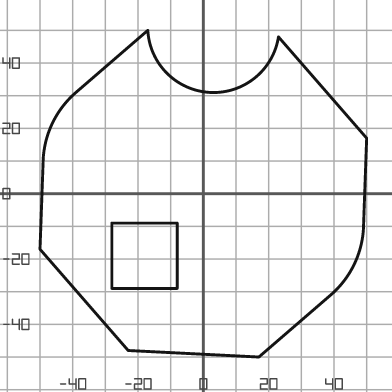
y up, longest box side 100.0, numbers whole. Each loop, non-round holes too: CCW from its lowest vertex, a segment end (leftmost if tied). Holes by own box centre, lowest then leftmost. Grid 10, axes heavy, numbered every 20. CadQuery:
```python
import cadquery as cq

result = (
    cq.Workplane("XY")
    .moveTo(17.0, -50.0)
    .lineTo(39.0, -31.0)
    .threePointArc((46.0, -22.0), (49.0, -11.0))
    .lineTo(50.0, 17.0)
    .lineTo(23.0, 48.0)
    .threePointArc((2.0, 31.0), (-17.0, 50.0))
    .lineTo(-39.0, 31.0)
    .threePointArc((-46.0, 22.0), (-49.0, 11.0))
    .lineTo(-50.0, -17.0)
    .lineTo(-23.0, -48.0)
    .close()
    .moveTo(-28.0, -29.0)
    .lineTo(-8.0, -29.0)
    .lineTo(-8.0, -9.0)
    .lineTo(-28.0, -9.0)
    .close()
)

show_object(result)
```